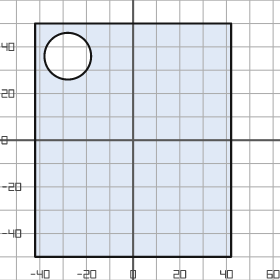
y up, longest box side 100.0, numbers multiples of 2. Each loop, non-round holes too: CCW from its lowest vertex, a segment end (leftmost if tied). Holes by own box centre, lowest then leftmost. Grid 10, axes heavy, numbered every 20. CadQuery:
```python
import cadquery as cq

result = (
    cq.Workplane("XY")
    .moveTo(-42.0, -50.0)
    .lineTo(42.0, -50.0)
    .lineTo(42.0, 50.0)
    .lineTo(-42.0, 50.0)
    .close()
    .moveTo(-28.0, 36.0)
    .circle(10.0)
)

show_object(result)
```